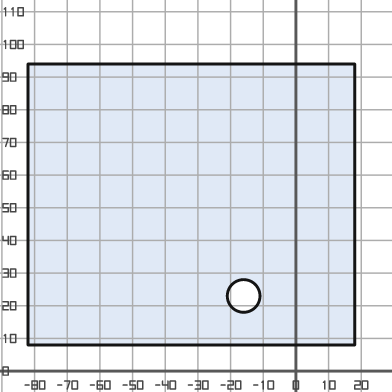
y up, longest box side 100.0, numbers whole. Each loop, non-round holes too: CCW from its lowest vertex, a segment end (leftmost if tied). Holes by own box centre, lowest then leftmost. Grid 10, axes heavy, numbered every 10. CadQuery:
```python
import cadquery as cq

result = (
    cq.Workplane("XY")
    .moveTo(-82.0, 8.0)
    .lineTo(18.0, 8.0)
    .lineTo(18.0, 94.0)
    .lineTo(-82.0, 94.0)
    .close()
    .moveTo(-16.0, 23.0)
    .circle(5.0)
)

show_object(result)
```